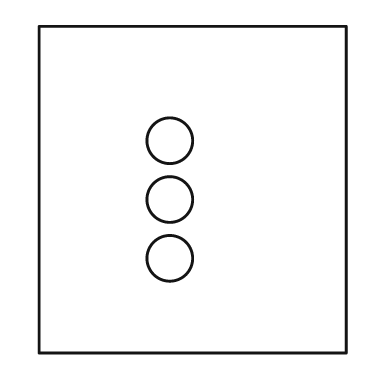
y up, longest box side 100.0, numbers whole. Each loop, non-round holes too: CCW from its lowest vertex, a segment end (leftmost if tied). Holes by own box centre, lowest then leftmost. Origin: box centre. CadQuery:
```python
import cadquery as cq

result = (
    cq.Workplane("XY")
    .moveTo(-47.0, -50.0)
    .lineTo(47.0, -50.0)
    .lineTo(47.0, 50.0)
    .lineTo(-47.0, 50.0)
    .close()
    .moveTo(-7.0, -21.0)
    .circle(7.0)
    .moveTo(-7.0, -3.0)
    .circle(7.0)
    .moveTo(-7.0, 15.0)
    .circle(7.0)
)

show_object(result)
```